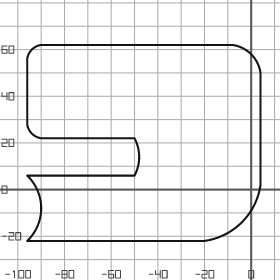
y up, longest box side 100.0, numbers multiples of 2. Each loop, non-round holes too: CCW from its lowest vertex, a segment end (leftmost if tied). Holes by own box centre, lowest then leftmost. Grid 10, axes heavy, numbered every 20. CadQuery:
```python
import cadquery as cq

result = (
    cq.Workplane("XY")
    .moveTo(-96.0, -22.0)
    .lineTo(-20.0, -22.0)
    .threePointArc((-4.0, -14.0), (4.0, 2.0))
    .lineTo(4.0, 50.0)
    .threePointArc((0.0, 58.0), (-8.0, 62.0))
    .lineTo(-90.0, 62.0)
    .threePointArc((-94.0, 60.0), (-96.0, 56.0))
    .lineTo(-96.0, 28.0)
    .threePointArc((-94.0, 24.0), (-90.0, 22.0))
    .lineTo(-50.0, 22.0)
    .threePointArc((-48.0, 14.0), (-50.0, 6.0))
    .lineTo(-96.0, 6.0)
    .threePointArc((-90.0, -8.0), (-96.0, -22.0))
    .close()
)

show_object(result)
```